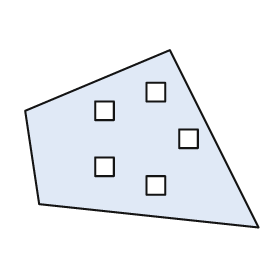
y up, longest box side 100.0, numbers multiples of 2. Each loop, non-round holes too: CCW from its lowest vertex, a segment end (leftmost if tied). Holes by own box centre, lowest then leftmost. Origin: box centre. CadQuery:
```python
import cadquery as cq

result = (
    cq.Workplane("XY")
    .moveTo(50.0, -38.0)
    .lineTo(12.0, 38.0)
    .lineTo(-50.0, 12.0)
    .lineTo(-44.0, -28.0)
    .close()
    .moveTo(2.0, -24.0)
    .lineTo(10.0, -24.0)
    .lineTo(10.0, -16.0)
    .lineTo(2.0, -16.0)
    .close()
    .moveTo(-20.0, -16.0)
    .lineTo(-12.0, -16.0)
    .lineTo(-12.0, -8.0)
    .lineTo(-20.0, -8.0)
    .close()
    .moveTo(16.0, -4.0)
    .lineTo(24.0, -4.0)
    .lineTo(24.0, 4.0)
    .lineTo(16.0, 4.0)
    .close()
    .moveTo(-20.0, 8.0)
    .lineTo(-12.0, 8.0)
    .lineTo(-12.0, 16.0)
    .lineTo(-20.0, 16.0)
    .close()
    .moveTo(2.0, 16.0)
    .lineTo(10.0, 16.0)
    .lineTo(10.0, 24.0)
    .lineTo(2.0, 24.0)
    .close()
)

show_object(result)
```